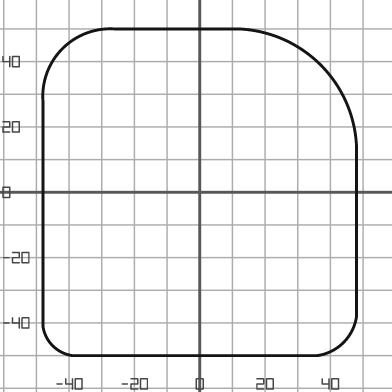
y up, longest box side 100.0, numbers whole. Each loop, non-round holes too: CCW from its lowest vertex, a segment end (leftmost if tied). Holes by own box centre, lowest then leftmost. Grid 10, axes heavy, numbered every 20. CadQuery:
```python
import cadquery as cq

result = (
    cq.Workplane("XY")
    .moveTo(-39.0, -50.0)
    .lineTo(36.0, -50.0)
    .threePointArc((44.0, -46.0), (48.0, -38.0))
    .lineTo(48.0, 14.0)
    .threePointArc((37.0, 39.0), (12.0, 50.0))
    .lineTo(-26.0, 50.0)
    .threePointArc((-42.0, 44.0), (-48.0, 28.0))
    .lineTo(-48.0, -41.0)
    .threePointArc((-45.0, -47.0), (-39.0, -50.0))
    .close()
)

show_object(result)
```